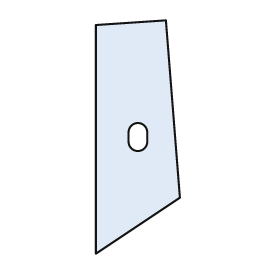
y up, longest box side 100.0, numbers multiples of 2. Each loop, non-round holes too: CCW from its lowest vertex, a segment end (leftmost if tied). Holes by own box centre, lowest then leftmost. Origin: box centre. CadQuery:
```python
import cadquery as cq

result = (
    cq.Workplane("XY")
    .moveTo(-18.0, -50.0)
    .lineTo(18.0, -26.0)
    .lineTo(12.0, 50.0)
    .lineTo(-18.0, 48.0)
    .close()
    .moveTo(-4.0, -2.0)
    .threePointArc((0.0, -6.0), (4.0, -2.0))
    .lineTo(4.0, 2.0)
    .threePointArc((0.0, 6.0), (-4.0, 2.0))
    .close()
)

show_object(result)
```